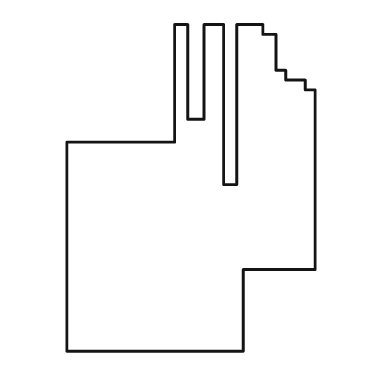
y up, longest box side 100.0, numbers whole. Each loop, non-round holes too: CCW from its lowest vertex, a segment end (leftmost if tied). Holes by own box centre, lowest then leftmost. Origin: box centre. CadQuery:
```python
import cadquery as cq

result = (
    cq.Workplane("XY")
    .moveTo(-38.0, -50.0)
    .lineTo(16.0, -50.0)
    .lineTo(16.0, -25.0)
    .lineTo(38.0, -25.0)
    .lineTo(38.0, 30.0)
    .lineTo(35.0, 30.0)
    .lineTo(35.0, 33.0)
    .lineTo(29.0, 33.0)
    .lineTo(29.0, 36.0)
    .lineTo(26.0, 36.0)
    .lineTo(26.0, 47.0)
    .lineTo(22.0, 47.0)
    .lineTo(22.0, 50.0)
    .lineTo(14.0, 50.0)
    .lineTo(14.0, 1.0)
    .lineTo(10.0, 1.0)
    .lineTo(10.0, 50.0)
    .lineTo(4.0, 50.0)
    .lineTo(4.0, 21.0)
    .lineTo(-1.0, 21.0)
    .lineTo(-1.0, 50.0)
    .lineTo(-5.0, 50.0)
    .lineTo(-5.0, 14.0)
    .lineTo(-38.0, 14.0)
    .close()
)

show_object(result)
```